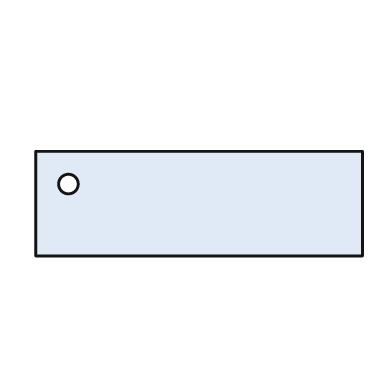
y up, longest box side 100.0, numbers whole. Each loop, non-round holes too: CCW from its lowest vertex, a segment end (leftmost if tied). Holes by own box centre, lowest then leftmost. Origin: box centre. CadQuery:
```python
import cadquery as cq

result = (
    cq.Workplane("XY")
    .moveTo(-50.0, -16.0)
    .lineTo(50.0, -16.0)
    .lineTo(50.0, 16.0)
    .lineTo(-50.0, 16.0)
    .close()
    .moveTo(-40.0, 6.0)
    .circle(3.0)
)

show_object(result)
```